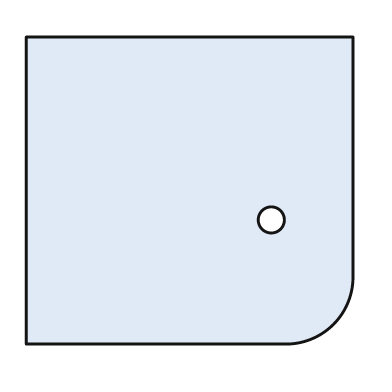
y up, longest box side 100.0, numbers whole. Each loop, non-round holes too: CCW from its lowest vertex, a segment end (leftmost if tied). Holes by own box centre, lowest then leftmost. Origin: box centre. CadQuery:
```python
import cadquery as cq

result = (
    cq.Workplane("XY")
    .moveTo(-50.0, -47.0)
    .lineTo(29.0, -47.0)
    .threePointArc((44.0, -41.0), (50.0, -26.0))
    .lineTo(50.0, 47.0)
    .lineTo(-50.0, 47.0)
    .close()
    .moveTo(25.0, -9.0)
    .circle(4.0)
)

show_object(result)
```